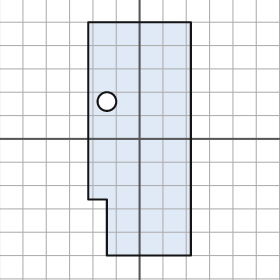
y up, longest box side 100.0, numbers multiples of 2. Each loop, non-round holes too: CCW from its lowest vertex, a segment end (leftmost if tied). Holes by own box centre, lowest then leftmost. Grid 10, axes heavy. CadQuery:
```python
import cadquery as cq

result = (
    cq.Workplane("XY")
    .moveTo(-14.0, -50.0)
    .lineTo(22.0, -50.0)
    .lineTo(22.0, 50.0)
    .lineTo(-22.0, 50.0)
    .lineTo(-22.0, -26.0)
    .lineTo(-14.0, -26.0)
    .close()
    .moveTo(-14.0, 16.0)
    .circle(4.0)
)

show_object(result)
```